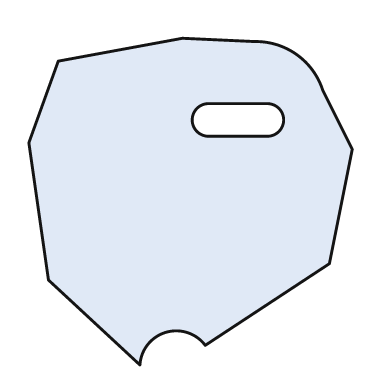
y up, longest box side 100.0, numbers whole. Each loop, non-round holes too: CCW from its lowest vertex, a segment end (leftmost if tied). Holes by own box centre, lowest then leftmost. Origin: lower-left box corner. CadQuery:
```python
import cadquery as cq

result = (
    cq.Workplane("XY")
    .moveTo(34.0, 0.0)
    .threePointArc((42.0, 10.0), (54.0, 6.0))
    .lineTo(92.0, 31.0)
    .lineTo(99.0, 66.0)
    .lineTo(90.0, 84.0)
    .threePointArc((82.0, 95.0), (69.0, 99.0))
    .lineTo(47.0, 100.0)
    .lineTo(9.0, 93.0)
    .lineTo(0.0, 68.0)
    .lineTo(6.0, 26.0)
    .close()
    .moveTo(55.0, 70.0)
    .lineTo(73.0, 70.0)
    .threePointArc((78.0, 75.0), (73.0, 80.0))
    .lineTo(55.0, 80.0)
    .threePointArc((50.0, 75.0), (55.0, 70.0))
    .close()
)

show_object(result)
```